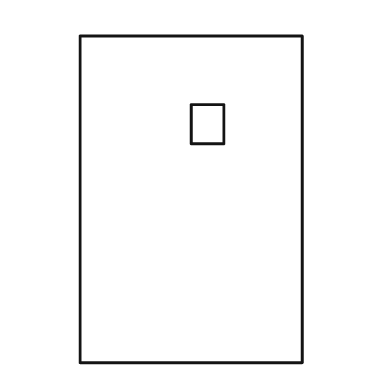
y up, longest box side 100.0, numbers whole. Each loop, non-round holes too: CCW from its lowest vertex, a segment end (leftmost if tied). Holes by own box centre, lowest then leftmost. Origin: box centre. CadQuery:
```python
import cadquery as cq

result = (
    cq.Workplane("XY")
    .moveTo(-34.0, -50.0)
    .lineTo(34.0, -50.0)
    .lineTo(34.0, 50.0)
    .lineTo(-34.0, 50.0)
    .close()
    .moveTo(0.0, 17.0)
    .lineTo(10.0, 17.0)
    .lineTo(10.0, 29.0)
    .lineTo(0.0, 29.0)
    .close()
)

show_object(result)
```